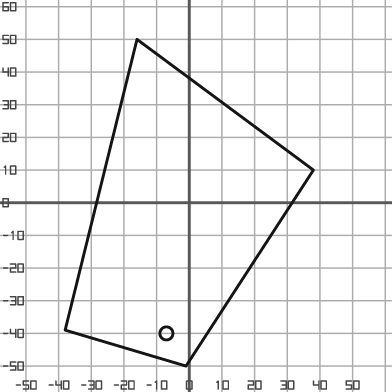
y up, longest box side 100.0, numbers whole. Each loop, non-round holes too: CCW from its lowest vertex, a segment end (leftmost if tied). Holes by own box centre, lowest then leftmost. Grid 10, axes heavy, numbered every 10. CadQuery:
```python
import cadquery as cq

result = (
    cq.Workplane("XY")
    .moveTo(-1.0, -50.0)
    .lineTo(38.0, 10.0)
    .lineTo(-16.0, 50.0)
    .lineTo(-38.0, -39.0)
    .close()
    .moveTo(-7.0, -40.0)
    .circle(2.0)
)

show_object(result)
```